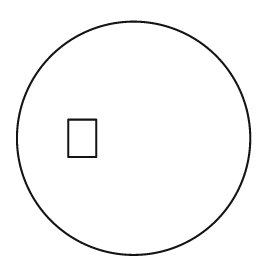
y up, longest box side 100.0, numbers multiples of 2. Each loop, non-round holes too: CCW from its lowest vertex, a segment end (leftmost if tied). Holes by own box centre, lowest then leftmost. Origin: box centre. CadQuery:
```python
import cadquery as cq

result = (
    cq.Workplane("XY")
    .moveTo(0.0, 0.0)
    .circle(50.0)
    .moveTo(-28.0, -8.0)
    .lineTo(-16.0, -8.0)
    .lineTo(-16.0, 8.0)
    .lineTo(-28.0, 8.0)
    .close()
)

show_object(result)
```